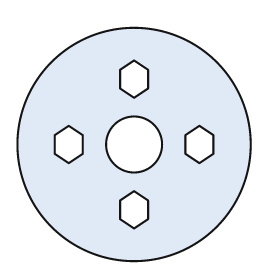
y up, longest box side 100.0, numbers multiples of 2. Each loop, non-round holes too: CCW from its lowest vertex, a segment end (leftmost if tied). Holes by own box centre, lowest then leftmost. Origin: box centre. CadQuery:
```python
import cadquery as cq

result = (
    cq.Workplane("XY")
    .moveTo(0.0, 0.0)
    .circle(50.0)
    .moveTo(0.0, -36.0)
    .lineTo(6.0, -32.0)
    .lineTo(6.0, -24.0)
    .lineTo(0.0, -20.0)
    .lineTo(-6.0, -24.0)
    .lineTo(-6.0, -32.0)
    .close()
    .moveTo(-28.0, -8.0)
    .lineTo(-22.0, -4.0)
    .lineTo(-22.0, 4.0)
    .lineTo(-28.0, 8.0)
    .lineTo(-34.0, 4.0)
    .lineTo(-34.0, -4.0)
    .close()
    .moveTo(0.0, 0.0)
    .circle(12.0)
    .moveTo(28.0, -8.0)
    .lineTo(34.0, -4.0)
    .lineTo(34.0, 4.0)
    .lineTo(28.0, 8.0)
    .lineTo(22.0, 4.0)
    .lineTo(22.0, -4.0)
    .close()
    .moveTo(0.0, 20.0)
    .lineTo(6.0, 24.0)
    .lineTo(6.0, 32.0)
    .lineTo(0.0, 36.0)
    .lineTo(-6.0, 32.0)
    .lineTo(-6.0, 24.0)
    .close()
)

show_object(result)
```